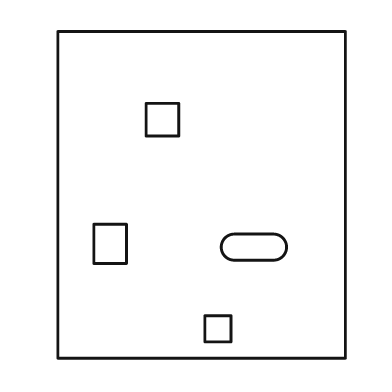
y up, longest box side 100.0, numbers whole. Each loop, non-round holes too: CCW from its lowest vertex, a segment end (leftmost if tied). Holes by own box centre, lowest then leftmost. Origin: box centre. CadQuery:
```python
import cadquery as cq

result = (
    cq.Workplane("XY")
    .moveTo(-44.0, -50.0)
    .lineTo(44.0, -50.0)
    .lineTo(44.0, 50.0)
    .lineTo(-44.0, 50.0)
    .close()
    .moveTo(1.0, -45.0)
    .lineTo(9.0, -45.0)
    .lineTo(9.0, -37.0)
    .lineTo(1.0, -37.0)
    .close()
    .moveTo(10.0, -20.0)
    .lineTo(22.0, -20.0)
    .threePointArc((26.0, -16.0), (22.0, -12.0))
    .lineTo(10.0, -12.0)
    .threePointArc((6.0, -16.0), (10.0, -20.0))
    .close()
    .moveTo(-33.0, -21.0)
    .lineTo(-23.0, -21.0)
    .lineTo(-23.0, -9.0)
    .lineTo(-33.0, -9.0)
    .close()
    .moveTo(-17.0, 18.0)
    .lineTo(-7.0, 18.0)
    .lineTo(-7.0, 28.0)
    .lineTo(-17.0, 28.0)
    .close()
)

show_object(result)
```